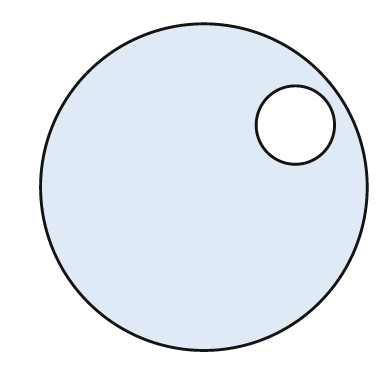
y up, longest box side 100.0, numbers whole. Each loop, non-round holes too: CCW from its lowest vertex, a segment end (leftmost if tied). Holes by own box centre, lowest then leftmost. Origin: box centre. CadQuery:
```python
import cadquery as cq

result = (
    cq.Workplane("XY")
    .moveTo(0.0, 0.0)
    .circle(50.0)
    .moveTo(28.0, 19.0)
    .circle(12.0)
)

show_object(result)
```